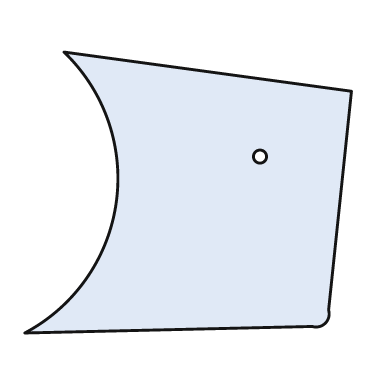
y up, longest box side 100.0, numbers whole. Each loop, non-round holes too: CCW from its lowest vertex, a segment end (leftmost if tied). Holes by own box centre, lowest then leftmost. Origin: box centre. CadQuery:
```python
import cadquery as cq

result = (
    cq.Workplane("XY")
    .moveTo(-50.0, -43.0)
    .lineTo(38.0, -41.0)
    .threePointArc((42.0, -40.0), (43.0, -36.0))
    .lineTo(50.0, 31.0)
    .lineTo(-38.0, 43.0)
    .threePointArc((-22.0, -3.0), (-50.0, -43.0))
    .close()
    .moveTo(22.0, 11.0)
    .circle(2.0)
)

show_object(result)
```